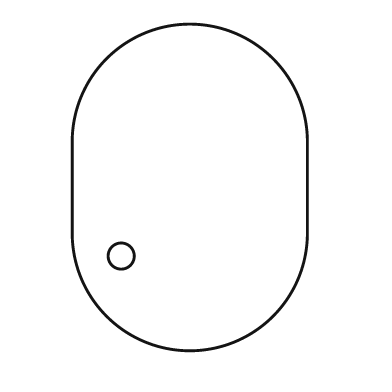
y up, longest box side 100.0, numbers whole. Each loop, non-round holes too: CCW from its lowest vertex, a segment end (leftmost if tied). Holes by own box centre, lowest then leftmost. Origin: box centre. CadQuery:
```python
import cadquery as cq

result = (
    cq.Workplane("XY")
    .moveTo(-36.0, -14.0)
    .threePointArc((0.0, -50.0), (36.0, -14.0))
    .lineTo(36.0, 14.0)
    .threePointArc((0.0, 50.0), (-36.0, 14.0))
    .close()
    .moveTo(-21.0, -21.0)
    .circle(4.0)
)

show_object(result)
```